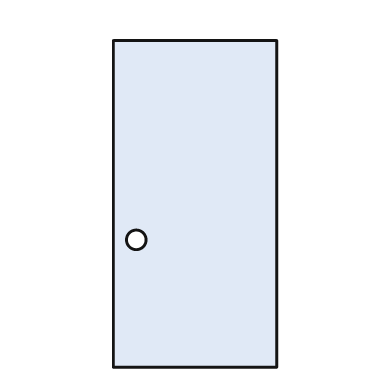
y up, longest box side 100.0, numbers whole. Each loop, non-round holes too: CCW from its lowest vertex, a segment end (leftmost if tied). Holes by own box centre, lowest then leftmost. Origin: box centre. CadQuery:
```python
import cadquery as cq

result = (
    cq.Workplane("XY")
    .moveTo(-25.0, -50.0)
    .lineTo(25.0, -50.0)
    .lineTo(25.0, 50.0)
    .lineTo(-25.0, 50.0)
    .close()
    .moveTo(-18.0, -11.0)
    .circle(3.0)
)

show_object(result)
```